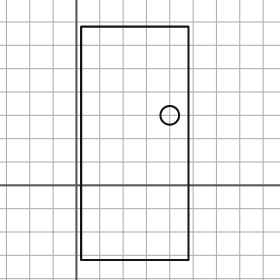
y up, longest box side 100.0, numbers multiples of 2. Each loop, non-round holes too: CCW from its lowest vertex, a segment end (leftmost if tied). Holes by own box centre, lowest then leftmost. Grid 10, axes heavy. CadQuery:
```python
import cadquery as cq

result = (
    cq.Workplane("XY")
    .moveTo(2.0, -32.0)
    .lineTo(48.0, -32.0)
    .lineTo(48.0, 68.0)
    .lineTo(2.0, 68.0)
    .close()
    .moveTo(40.0, 30.0)
    .circle(4.0)
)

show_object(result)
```